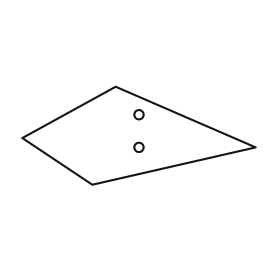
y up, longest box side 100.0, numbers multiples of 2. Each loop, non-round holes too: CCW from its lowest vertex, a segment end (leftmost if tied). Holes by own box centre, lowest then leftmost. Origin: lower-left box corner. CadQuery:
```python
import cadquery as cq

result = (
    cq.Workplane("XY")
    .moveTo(30.0, 0.0)
    .lineTo(100.0, 16.0)
    .lineTo(40.0, 42.0)
    .lineTo(0.0, 20.0)
    .close()
    .moveTo(50.0, 16.0)
    .circle(2.0)
    .moveTo(50.0, 30.0)
    .circle(2.0)
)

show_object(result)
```